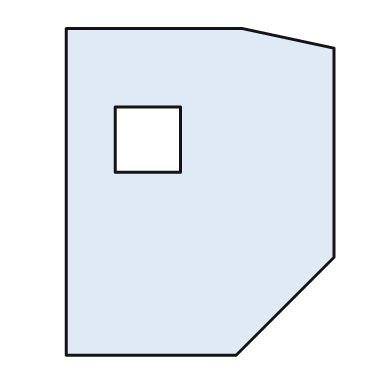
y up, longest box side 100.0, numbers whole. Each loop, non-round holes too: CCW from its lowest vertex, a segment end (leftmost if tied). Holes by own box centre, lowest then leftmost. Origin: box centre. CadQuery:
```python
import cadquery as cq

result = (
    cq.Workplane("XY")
    .moveTo(-41.0, -50.0)
    .lineTo(11.0, -50.0)
    .lineTo(41.0, -20.0)
    .lineTo(41.0, 44.0)
    .lineTo(13.0, 50.0)
    .lineTo(-41.0, 50.0)
    .close()
    .moveTo(-26.0, 6.0)
    .lineTo(-6.0, 6.0)
    .lineTo(-6.0, 26.0)
    .lineTo(-26.0, 26.0)
    .close()
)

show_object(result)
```